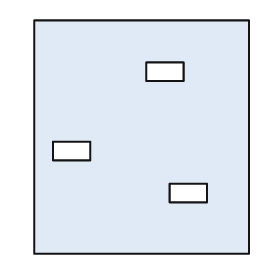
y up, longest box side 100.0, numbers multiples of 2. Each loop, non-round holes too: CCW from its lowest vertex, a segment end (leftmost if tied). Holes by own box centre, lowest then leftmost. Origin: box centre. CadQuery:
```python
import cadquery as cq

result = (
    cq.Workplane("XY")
    .moveTo(-46.0, -50.0)
    .lineTo(46.0, -50.0)
    .lineTo(46.0, 50.0)
    .lineTo(-46.0, 50.0)
    .close()
    .moveTo(12.0, -28.0)
    .lineTo(28.0, -28.0)
    .lineTo(28.0, -20.0)
    .lineTo(12.0, -20.0)
    .close()
    .moveTo(-38.0, -10.0)
    .lineTo(-22.0, -10.0)
    .lineTo(-22.0, -2.0)
    .lineTo(-38.0, -2.0)
    .close()
    .moveTo(2.0, 24.0)
    .lineTo(18.0, 24.0)
    .lineTo(18.0, 32.0)
    .lineTo(2.0, 32.0)
    .close()
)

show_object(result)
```